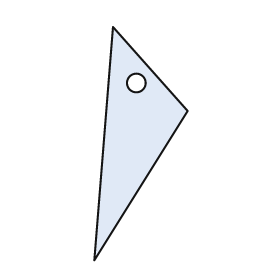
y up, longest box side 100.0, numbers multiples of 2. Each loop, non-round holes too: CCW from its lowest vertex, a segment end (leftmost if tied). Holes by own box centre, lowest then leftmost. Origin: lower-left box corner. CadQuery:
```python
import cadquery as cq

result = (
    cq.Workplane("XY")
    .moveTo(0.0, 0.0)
    .lineTo(40.0, 64.0)
    .lineTo(8.0, 100.0)
    .close()
    .moveTo(18.0, 76.0)
    .circle(4.0)
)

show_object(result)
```